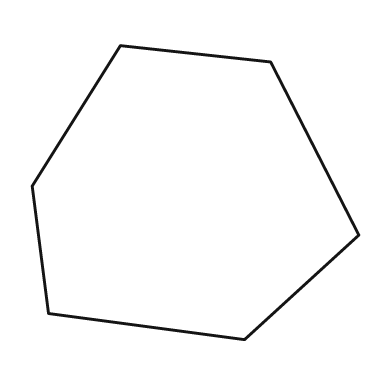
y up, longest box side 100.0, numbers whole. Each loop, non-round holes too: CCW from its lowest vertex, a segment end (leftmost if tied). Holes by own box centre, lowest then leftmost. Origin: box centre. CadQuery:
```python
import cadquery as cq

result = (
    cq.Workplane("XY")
    .moveTo(15.0, -45.0)
    .lineTo(50.0, -13.0)
    .lineTo(23.0, 40.0)
    .lineTo(-23.0, 45.0)
    .lineTo(-50.0, 2.0)
    .lineTo(-45.0, -37.0)
    .close()
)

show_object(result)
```